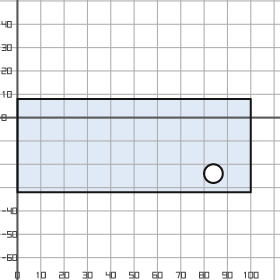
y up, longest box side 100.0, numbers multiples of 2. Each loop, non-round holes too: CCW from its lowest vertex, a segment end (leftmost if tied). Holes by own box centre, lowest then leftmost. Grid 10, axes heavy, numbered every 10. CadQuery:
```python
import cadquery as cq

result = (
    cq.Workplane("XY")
    .moveTo(0.0, -32.0)
    .lineTo(100.0, -32.0)
    .lineTo(100.0, 8.0)
    .lineTo(0.0, 8.0)
    .close()
    .moveTo(84.0, -24.0)
    .circle(4.0)
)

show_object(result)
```